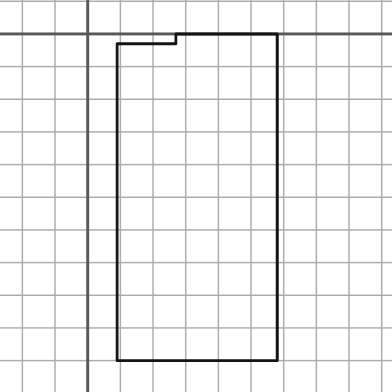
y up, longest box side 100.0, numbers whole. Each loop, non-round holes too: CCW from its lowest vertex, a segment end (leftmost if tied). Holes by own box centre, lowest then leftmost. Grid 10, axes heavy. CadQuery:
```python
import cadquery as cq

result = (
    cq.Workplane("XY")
    .moveTo(9.0, -100.0)
    .lineTo(58.0, -100.0)
    .lineTo(58.0, 0.0)
    .lineTo(27.0, 0.0)
    .lineTo(27.0, -3.0)
    .lineTo(9.0, -3.0)
    .close()
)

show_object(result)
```